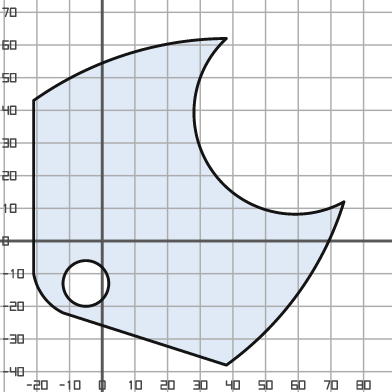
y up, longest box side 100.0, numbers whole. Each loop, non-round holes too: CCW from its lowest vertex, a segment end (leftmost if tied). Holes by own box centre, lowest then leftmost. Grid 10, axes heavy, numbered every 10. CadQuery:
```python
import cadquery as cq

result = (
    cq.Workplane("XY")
    .moveTo(38.0, -38.0)
    .threePointArc((60.0, -16.0), (74.0, 12.0))
    .threePointArc((34.0, 21.0), (38.0, 62.0))
    .threePointArc((7.0, 57.0), (-21.0, 43.0))
    .lineTo(-21.0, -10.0)
    .threePointArc((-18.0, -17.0), (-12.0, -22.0))
    .close()
    .moveTo(-5.0, -13.0)
    .circle(7.0)
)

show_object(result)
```